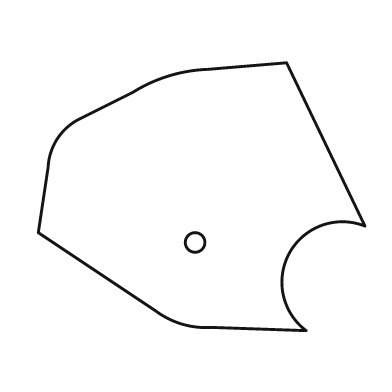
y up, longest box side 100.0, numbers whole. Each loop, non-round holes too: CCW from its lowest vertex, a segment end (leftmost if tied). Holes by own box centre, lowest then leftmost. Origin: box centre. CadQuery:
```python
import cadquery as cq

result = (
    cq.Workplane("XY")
    .moveTo(32.0, -41.0)
    .threePointArc((27.0, -17.0), (50.0, -9.0))
    .lineTo(26.0, 41.0)
    .lineTo(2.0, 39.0)
    .threePointArc((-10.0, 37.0), (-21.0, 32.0))
    .lineTo(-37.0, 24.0)
    .threePointArc((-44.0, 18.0), (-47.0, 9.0))
    .lineTo(-50.0, -11.0)
    .lineTo(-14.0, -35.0)
    .threePointArc((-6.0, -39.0), (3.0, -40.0))
    .close()
    .moveTo(-2.0, -14.0)
    .circle(3.0)
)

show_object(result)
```